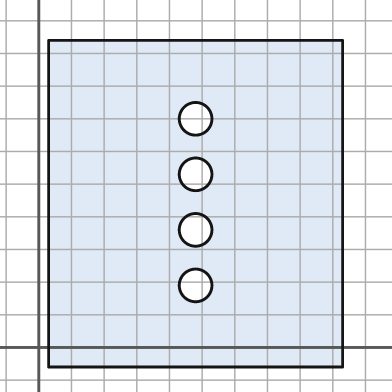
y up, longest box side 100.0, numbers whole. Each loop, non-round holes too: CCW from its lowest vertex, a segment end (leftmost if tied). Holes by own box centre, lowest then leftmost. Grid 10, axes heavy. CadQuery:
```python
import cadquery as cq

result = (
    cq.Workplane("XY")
    .moveTo(3.0, -6.0)
    .lineTo(93.0, -6.0)
    .lineTo(93.0, 94.0)
    .lineTo(3.0, 94.0)
    .close()
    .moveTo(48.0, 19.0)
    .circle(5.0)
    .moveTo(48.0, 36.0)
    .circle(5.0)
    .moveTo(48.0, 53.0)
    .circle(5.0)
    .moveTo(48.0, 70.0)
    .circle(5.0)
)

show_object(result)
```